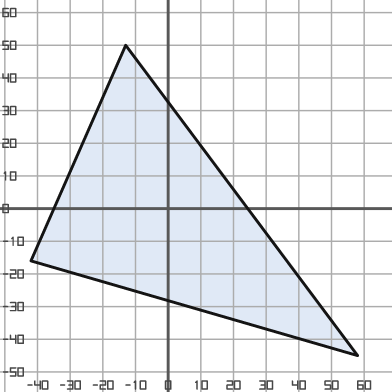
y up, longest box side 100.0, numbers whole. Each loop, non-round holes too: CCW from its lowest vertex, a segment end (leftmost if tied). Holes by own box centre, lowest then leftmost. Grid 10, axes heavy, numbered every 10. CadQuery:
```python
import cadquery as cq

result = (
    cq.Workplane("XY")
    .moveTo(58.0, -45.0)
    .lineTo(-13.0, 50.0)
    .lineTo(-42.0, -16.0)
    .close()
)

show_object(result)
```